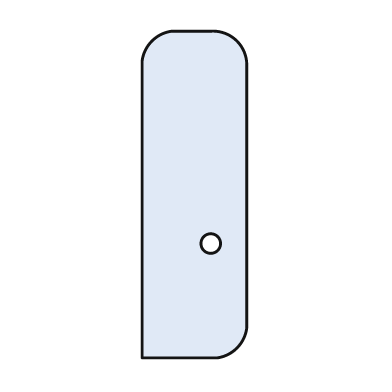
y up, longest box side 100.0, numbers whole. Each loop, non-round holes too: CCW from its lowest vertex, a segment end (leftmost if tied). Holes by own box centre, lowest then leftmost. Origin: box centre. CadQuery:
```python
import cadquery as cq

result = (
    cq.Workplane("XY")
    .moveTo(-16.0, -50.0)
    .lineTo(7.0, -50.0)
    .threePointArc((13.0, -47.0), (16.0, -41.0))
    .lineTo(16.0, 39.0)
    .threePointArc((13.0, 47.0), (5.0, 50.0))
    .lineTo(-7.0, 50.0)
    .threePointArc((-13.0, 47.0), (-16.0, 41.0))
    .close()
    .moveTo(5.0, -15.0)
    .circle(3.0)
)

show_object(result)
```